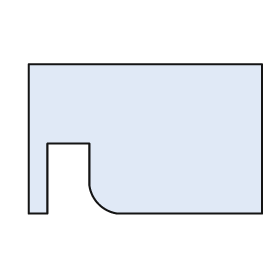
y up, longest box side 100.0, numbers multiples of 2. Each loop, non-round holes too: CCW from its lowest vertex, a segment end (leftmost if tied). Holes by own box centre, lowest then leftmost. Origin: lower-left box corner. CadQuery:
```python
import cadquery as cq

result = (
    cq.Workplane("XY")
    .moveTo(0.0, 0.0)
    .lineTo(8.0, 0.0)
    .lineTo(8.0, 30.0)
    .lineTo(26.0, 30.0)
    .lineTo(26.0, 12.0)
    .threePointArc((30.0, 4.0), (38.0, 0.0))
    .lineTo(100.0, 0.0)
    .lineTo(100.0, 64.0)
    .lineTo(0.0, 64.0)
    .close()
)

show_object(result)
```